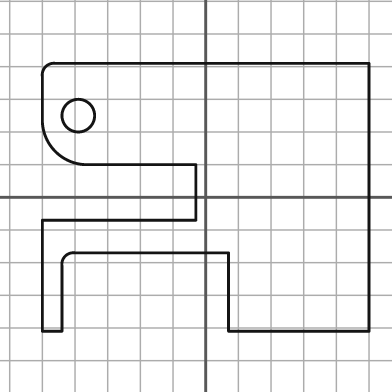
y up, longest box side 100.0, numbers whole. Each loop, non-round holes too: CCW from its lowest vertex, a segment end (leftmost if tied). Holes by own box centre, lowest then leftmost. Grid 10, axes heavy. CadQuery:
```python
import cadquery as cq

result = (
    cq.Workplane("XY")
    .moveTo(-50.0, -41.0)
    .lineTo(-44.0, -41.0)
    .lineTo(-44.0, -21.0)
    .threePointArc((-43.0, -18.0), (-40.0, -17.0))
    .lineTo(7.0, -17.0)
    .lineTo(7.0, -41.0)
    .lineTo(50.0, -41.0)
    .lineTo(50.0, 41.0)
    .lineTo(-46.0, 41.0)
    .threePointArc((-49.0, 40.0), (-50.0, 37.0))
    .lineTo(-50.0, 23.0)
    .threePointArc((-46.0, 14.0), (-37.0, 10.0))
    .lineTo(-3.0, 10.0)
    .lineTo(-3.0, -7.0)
    .lineTo(-50.0, -7.0)
    .close()
    .moveTo(-39.0, 25.0)
    .circle(5.0)
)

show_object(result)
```